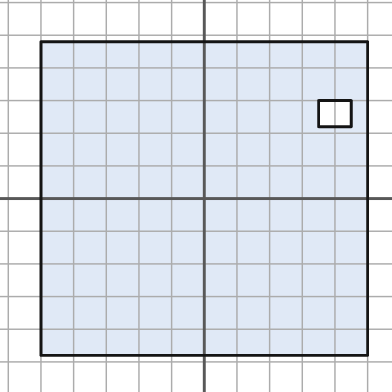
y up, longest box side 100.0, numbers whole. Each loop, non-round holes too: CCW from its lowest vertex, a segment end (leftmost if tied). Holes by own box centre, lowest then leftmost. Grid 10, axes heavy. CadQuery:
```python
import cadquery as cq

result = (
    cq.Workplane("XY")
    .moveTo(-50.0, -48.0)
    .lineTo(50.0, -48.0)
    .lineTo(50.0, 48.0)
    .lineTo(-50.0, 48.0)
    .close()
    .moveTo(35.0, 22.0)
    .lineTo(45.0, 22.0)
    .lineTo(45.0, 30.0)
    .lineTo(35.0, 30.0)
    .close()
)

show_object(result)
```